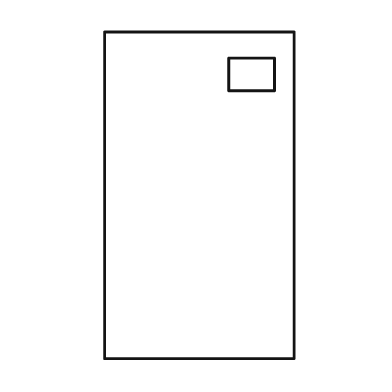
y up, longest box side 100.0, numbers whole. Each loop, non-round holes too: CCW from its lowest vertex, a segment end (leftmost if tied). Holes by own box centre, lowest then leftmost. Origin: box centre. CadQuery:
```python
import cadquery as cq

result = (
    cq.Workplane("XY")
    .moveTo(-29.0, -50.0)
    .lineTo(29.0, -50.0)
    .lineTo(29.0, 50.0)
    .lineTo(-29.0, 50.0)
    .close()
    .moveTo(9.0, 32.0)
    .lineTo(23.0, 32.0)
    .lineTo(23.0, 42.0)
    .lineTo(9.0, 42.0)
    .close()
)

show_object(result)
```